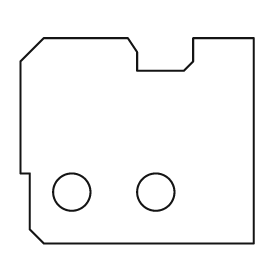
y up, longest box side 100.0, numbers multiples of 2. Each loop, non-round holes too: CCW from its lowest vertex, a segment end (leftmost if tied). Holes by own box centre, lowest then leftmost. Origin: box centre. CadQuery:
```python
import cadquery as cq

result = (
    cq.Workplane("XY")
    .moveTo(-40.0, -44.0)
    .lineTo(50.0, -44.0)
    .lineTo(50.0, 44.0)
    .lineTo(24.0, 44.0)
    .lineTo(24.0, 34.0)
    .lineTo(20.0, 30.0)
    .lineTo(0.0, 30.0)
    .lineTo(0.0, 38.0)
    .lineTo(-4.0, 44.0)
    .lineTo(-40.0, 44.0)
    .lineTo(-50.0, 34.0)
    .lineTo(-50.0, -14.0)
    .lineTo(-46.0, -14.0)
    .lineTo(-46.0, -38.0)
    .close()
    .moveTo(-28.0, -22.0)
    .circle(8.0)
    .moveTo(8.0, -22.0)
    .circle(8.0)
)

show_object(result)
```